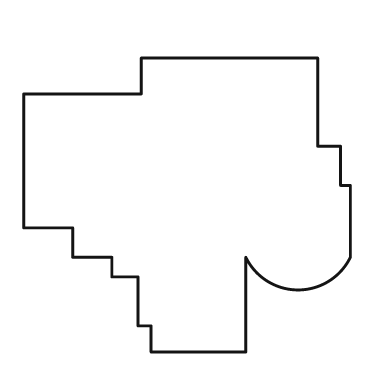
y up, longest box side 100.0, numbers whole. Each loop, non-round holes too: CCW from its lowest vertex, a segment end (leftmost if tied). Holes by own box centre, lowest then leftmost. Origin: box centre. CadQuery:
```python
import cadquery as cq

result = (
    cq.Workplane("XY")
    .moveTo(-11.0, -45.0)
    .lineTo(18.0, -45.0)
    .lineTo(18.0, -16.0)
    .threePointArc((34.0, -26.0), (50.0, -16.0))
    .lineTo(50.0, 6.0)
    .lineTo(47.0, 6.0)
    .lineTo(47.0, 18.0)
    .lineTo(40.0, 18.0)
    .lineTo(40.0, 45.0)
    .lineTo(-14.0, 45.0)
    .lineTo(-14.0, 34.0)
    .lineTo(-50.0, 34.0)
    .lineTo(-50.0, -7.0)
    .lineTo(-35.0, -7.0)
    .lineTo(-35.0, -16.0)
    .lineTo(-23.0, -16.0)
    .lineTo(-23.0, -22.0)
    .lineTo(-15.0, -22.0)
    .lineTo(-15.0, -37.0)
    .lineTo(-11.0, -37.0)
    .close()
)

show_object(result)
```